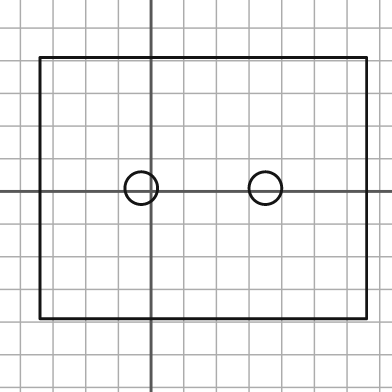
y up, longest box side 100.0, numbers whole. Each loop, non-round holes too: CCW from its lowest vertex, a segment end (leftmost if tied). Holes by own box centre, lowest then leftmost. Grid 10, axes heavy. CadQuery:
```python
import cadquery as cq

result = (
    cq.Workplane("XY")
    .moveTo(-34.0, -39.0)
    .lineTo(66.0, -39.0)
    .lineTo(66.0, 41.0)
    .lineTo(-34.0, 41.0)
    .close()
    .moveTo(-3.0, 1.0)
    .circle(5.0)
    .moveTo(35.0, 1.0)
    .circle(5.0)
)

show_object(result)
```